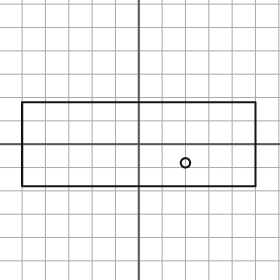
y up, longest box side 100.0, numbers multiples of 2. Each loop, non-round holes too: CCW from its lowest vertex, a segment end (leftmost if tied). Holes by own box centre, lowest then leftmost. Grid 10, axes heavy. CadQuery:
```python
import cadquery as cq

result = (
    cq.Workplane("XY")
    .moveTo(-50.0, -18.0)
    .lineTo(50.0, -18.0)
    .lineTo(50.0, 18.0)
    .lineTo(-50.0, 18.0)
    .close()
    .moveTo(20.0, -8.0)
    .circle(2.0)
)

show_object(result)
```